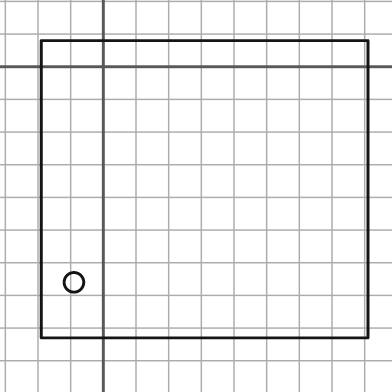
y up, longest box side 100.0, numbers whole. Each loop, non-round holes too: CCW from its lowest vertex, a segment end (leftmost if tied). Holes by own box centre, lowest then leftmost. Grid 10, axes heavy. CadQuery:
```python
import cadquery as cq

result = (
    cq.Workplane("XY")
    .moveTo(-19.0, -83.0)
    .lineTo(81.0, -83.0)
    .lineTo(81.0, 8.0)
    .lineTo(-19.0, 8.0)
    .close()
    .moveTo(-9.0, -66.0)
    .circle(3.0)
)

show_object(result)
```